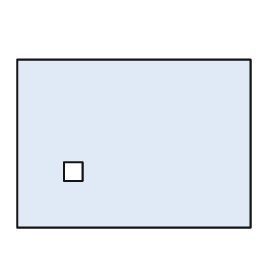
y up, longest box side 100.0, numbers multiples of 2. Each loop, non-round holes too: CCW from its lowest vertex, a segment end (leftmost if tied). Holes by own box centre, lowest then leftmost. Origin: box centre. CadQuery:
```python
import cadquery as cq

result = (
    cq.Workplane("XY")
    .moveTo(-50.0, -36.0)
    .lineTo(50.0, -36.0)
    .lineTo(50.0, 36.0)
    .lineTo(-50.0, 36.0)
    .close()
    .moveTo(-30.0, -16.0)
    .lineTo(-22.0, -16.0)
    .lineTo(-22.0, -8.0)
    .lineTo(-30.0, -8.0)
    .close()
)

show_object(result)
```